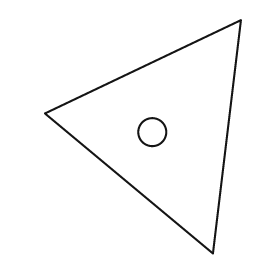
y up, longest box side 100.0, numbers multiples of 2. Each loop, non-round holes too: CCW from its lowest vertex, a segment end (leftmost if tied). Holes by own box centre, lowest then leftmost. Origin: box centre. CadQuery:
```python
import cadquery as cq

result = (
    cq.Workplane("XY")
    .moveTo(30.0, -50.0)
    .lineTo(42.0, 50.0)
    .lineTo(-42.0, 10.0)
    .close()
    .moveTo(4.0, 2.0)
    .circle(6.0)
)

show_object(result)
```